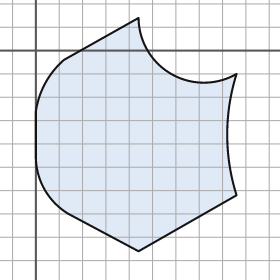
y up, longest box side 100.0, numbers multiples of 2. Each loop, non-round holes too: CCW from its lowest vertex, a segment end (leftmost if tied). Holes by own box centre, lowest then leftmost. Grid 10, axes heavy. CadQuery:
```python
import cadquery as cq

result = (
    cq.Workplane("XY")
    .moveTo(44.0, -86.0)
    .lineTo(86.0, -62.0)
    .threePointArc((82.0, -36.0), (86.0, -10.0))
    .threePointArc((58.0, -10.0), (44.0, 14.0))
    .lineTo(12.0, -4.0)
    .threePointArc((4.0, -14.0), (0.0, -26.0))
    .lineTo(0.0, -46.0)
    .threePointArc((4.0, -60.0), (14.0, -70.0))
    .close()
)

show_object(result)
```